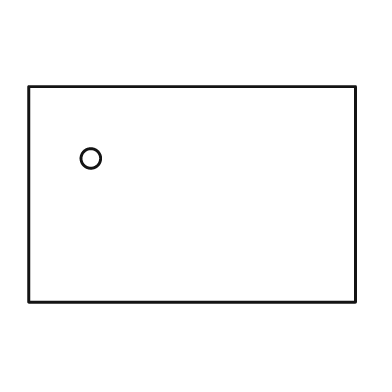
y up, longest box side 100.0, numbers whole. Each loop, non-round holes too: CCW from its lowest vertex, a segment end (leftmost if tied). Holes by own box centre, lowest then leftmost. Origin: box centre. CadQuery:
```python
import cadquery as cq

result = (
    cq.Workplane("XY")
    .moveTo(-50.0, -33.0)
    .lineTo(50.0, -33.0)
    .lineTo(50.0, 33.0)
    .lineTo(-50.0, 33.0)
    .close()
    .moveTo(-31.0, 11.0)
    .circle(3.0)
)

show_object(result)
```